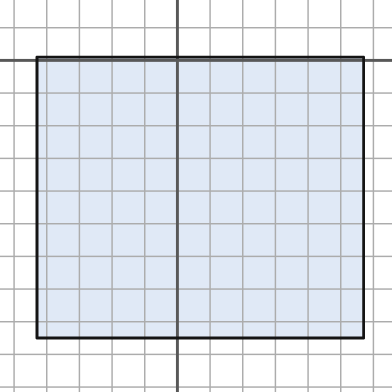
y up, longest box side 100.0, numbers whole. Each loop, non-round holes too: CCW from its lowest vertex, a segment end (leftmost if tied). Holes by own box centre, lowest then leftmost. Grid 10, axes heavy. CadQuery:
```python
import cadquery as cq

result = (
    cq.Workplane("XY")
    .moveTo(-43.0, -85.0)
    .lineTo(57.0, -85.0)
    .lineTo(57.0, 1.0)
    .lineTo(-43.0, 1.0)
    .close()
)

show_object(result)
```